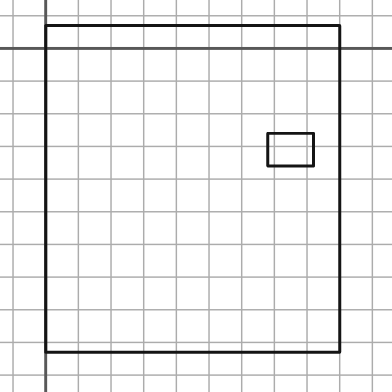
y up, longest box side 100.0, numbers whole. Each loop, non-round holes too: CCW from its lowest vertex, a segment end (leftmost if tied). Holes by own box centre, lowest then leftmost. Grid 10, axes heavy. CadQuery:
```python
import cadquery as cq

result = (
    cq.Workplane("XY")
    .moveTo(0.0, -93.0)
    .lineTo(90.0, -93.0)
    .lineTo(90.0, 7.0)
    .lineTo(0.0, 7.0)
    .close()
    .moveTo(68.0, -36.0)
    .lineTo(82.0, -36.0)
    .lineTo(82.0, -26.0)
    .lineTo(68.0, -26.0)
    .close()
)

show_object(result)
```